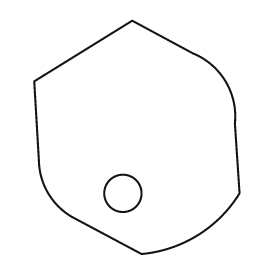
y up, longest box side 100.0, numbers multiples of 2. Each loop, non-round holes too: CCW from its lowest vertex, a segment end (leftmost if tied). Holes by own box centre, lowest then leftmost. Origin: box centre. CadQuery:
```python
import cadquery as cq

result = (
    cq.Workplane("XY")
    .moveTo(2.0, -50.0)
    .threePointArc((26.0, -42.0), (44.0, -24.0))
    .lineTo(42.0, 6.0)
    .threePointArc((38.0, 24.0), (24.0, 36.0))
    .lineTo(-2.0, 50.0)
    .lineTo(-44.0, 24.0)
    .lineTo(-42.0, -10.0)
    .threePointArc((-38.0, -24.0), (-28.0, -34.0))
    .close()
    .moveTo(-6.0, -24.0)
    .circle(8.0)
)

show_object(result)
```